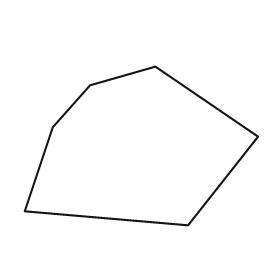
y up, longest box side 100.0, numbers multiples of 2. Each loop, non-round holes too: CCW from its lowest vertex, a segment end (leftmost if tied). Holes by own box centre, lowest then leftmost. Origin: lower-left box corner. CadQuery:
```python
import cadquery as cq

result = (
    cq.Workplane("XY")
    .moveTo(70.0, 0.0)
    .lineTo(100.0, 38.0)
    .lineTo(56.0, 68.0)
    .lineTo(28.0, 60.0)
    .lineTo(12.0, 42.0)
    .lineTo(0.0, 6.0)
    .close()
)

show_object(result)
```